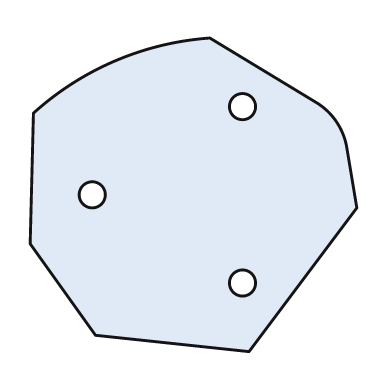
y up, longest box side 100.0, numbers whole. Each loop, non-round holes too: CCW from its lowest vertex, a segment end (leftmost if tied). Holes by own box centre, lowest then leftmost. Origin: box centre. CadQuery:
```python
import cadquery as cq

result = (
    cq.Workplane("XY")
    .moveTo(17.0, -48.0)
    .lineTo(50.0, -4.0)
    .lineTo(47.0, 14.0)
    .threePointArc((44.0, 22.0), (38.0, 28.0))
    .lineTo(5.0, 48.0)
    .threePointArc((-24.0, 41.0), (-49.0, 25.0))
    .lineTo(-50.0, -15.0)
    .lineTo(-30.0, -43.0)
    .close()
    .moveTo(15.0, -27.0)
    .circle(4.0)
    .moveTo(-31.0, 0.0)
    .circle(4.0)
    .moveTo(15.0, 27.0)
    .circle(4.0)
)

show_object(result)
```